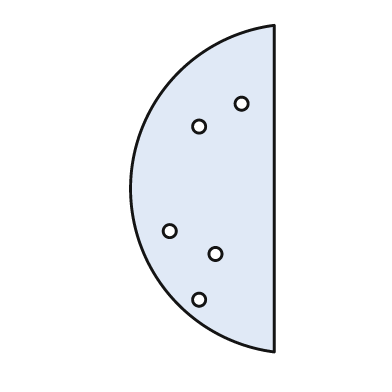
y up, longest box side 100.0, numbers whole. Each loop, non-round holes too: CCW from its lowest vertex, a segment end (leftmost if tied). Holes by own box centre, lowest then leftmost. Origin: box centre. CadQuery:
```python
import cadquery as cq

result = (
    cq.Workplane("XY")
    .moveTo(22.0, -50.0)
    .lineTo(22.0, 50.0)
    .threePointArc((-22.0, 0.0), (22.0, -50.0))
    .close()
    .moveTo(-1.0, -34.0)
    .circle(2.0)
    .moveTo(4.0, -20.0)
    .circle(2.0)
    .moveTo(-10.0, -13.0)
    .circle(2.0)
    .moveTo(-1.0, 19.0)
    .circle(2.0)
    .moveTo(12.0, 26.0)
    .circle(2.0)
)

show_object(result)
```